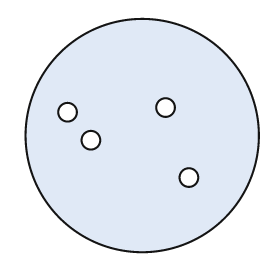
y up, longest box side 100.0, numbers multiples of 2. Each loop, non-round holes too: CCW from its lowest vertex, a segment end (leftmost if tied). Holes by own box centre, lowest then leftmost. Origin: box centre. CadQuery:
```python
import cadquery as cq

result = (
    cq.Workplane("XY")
    .moveTo(0.0, 0.0)
    .circle(50.0)
    .moveTo(20.0, -18.0)
    .circle(4.0)
    .moveTo(-22.0, -2.0)
    .circle(4.0)
    .moveTo(-32.0, 10.0)
    .circle(4.0)
    .moveTo(10.0, 12.0)
    .circle(4.0)
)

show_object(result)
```